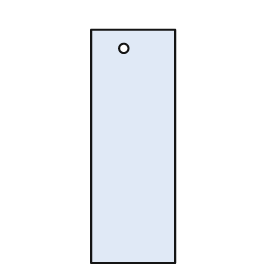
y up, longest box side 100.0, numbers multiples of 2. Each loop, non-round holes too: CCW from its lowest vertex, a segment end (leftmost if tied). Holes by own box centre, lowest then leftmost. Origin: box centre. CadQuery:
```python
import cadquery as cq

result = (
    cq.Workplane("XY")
    .moveTo(-18.0, -50.0)
    .lineTo(18.0, -50.0)
    .lineTo(18.0, 50.0)
    .lineTo(-18.0, 50.0)
    .close()
    .moveTo(-4.0, 42.0)
    .circle(2.0)
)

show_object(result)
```